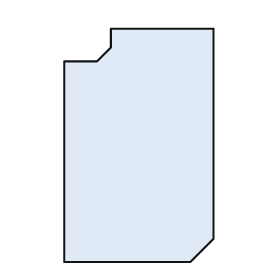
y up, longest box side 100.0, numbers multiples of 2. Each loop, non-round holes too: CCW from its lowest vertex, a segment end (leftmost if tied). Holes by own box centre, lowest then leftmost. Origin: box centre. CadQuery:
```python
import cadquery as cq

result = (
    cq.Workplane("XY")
    .moveTo(-32.0, -50.0)
    .lineTo(22.0, -50.0)
    .lineTo(32.0, -40.0)
    .lineTo(32.0, 50.0)
    .lineTo(-12.0, 50.0)
    .lineTo(-12.0, 42.0)
    .lineTo(-18.0, 36.0)
    .lineTo(-32.0, 36.0)
    .close()
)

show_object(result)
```